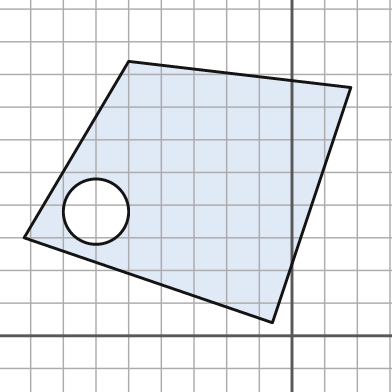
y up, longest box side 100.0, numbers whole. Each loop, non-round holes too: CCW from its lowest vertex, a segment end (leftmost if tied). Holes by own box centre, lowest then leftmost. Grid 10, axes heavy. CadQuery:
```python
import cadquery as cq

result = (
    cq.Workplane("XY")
    .moveTo(-6.0, 4.0)
    .lineTo(18.0, 76.0)
    .lineTo(-50.0, 84.0)
    .lineTo(-82.0, 30.0)
    .close()
    .moveTo(-60.0, 38.0)
    .circle(10.0)
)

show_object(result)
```